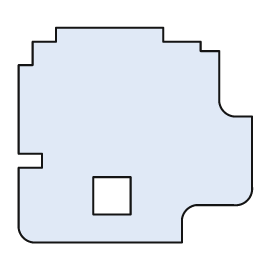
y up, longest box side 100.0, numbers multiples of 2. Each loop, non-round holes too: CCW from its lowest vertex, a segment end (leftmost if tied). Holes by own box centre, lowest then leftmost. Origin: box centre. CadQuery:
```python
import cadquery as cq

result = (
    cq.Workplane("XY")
    .moveTo(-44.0, -46.0)
    .lineTo(20.0, -46.0)
    .lineTo(20.0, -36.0)
    .threePointArc((22.0, -32.0), (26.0, -30.0))
    .lineTo(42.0, -30.0)
    .threePointArc((48.0, -28.0), (50.0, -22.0))
    .lineTo(50.0, 8.0)
    .lineTo(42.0, 8.0)
    .threePointArc((38.0, 10.0), (36.0, 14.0))
    .lineTo(36.0, 36.0)
    .lineTo(28.0, 36.0)
    .lineTo(28.0, 40.0)
    .lineTo(12.0, 40.0)
    .lineTo(12.0, 46.0)
    .lineTo(-34.0, 46.0)
    .lineTo(-34.0, 40.0)
    .lineTo(-44.0, 40.0)
    .lineTo(-44.0, 30.0)
    .lineTo(-50.0, 30.0)
    .lineTo(-50.0, -8.0)
    .lineTo(-40.0, -8.0)
    .lineTo(-40.0, -14.0)
    .lineTo(-50.0, -14.0)
    .lineTo(-50.0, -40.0)
    .threePointArc((-48.0, -44.0), (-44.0, -46.0))
    .close()
    .moveTo(-18.0, -34.0)
    .lineTo(-2.0, -34.0)
    .lineTo(-2.0, -18.0)
    .lineTo(-18.0, -18.0)
    .close()
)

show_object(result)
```